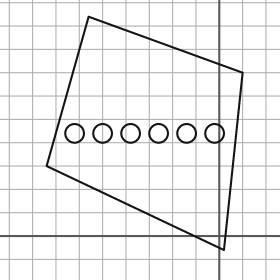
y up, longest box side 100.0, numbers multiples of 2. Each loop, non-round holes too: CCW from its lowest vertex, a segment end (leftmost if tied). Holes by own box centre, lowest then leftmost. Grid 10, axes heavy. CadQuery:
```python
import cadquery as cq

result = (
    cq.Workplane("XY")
    .moveTo(2.0, -6.0)
    .lineTo(10.0, 70.0)
    .lineTo(-56.0, 94.0)
    .lineTo(-74.0, 30.0)
    .close()
    .moveTo(-62.0, 44.0)
    .circle(4.0)
    .moveTo(-50.0, 44.0)
    .circle(4.0)
    .moveTo(-38.0, 44.0)
    .circle(4.0)
    .moveTo(-26.0, 44.0)
    .circle(4.0)
    .moveTo(-14.0, 44.0)
    .circle(4.0)
    .moveTo(-2.0, 44.0)
    .circle(4.0)
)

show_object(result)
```